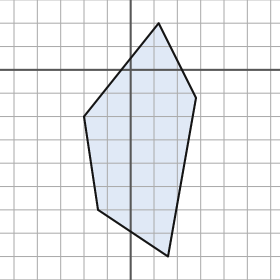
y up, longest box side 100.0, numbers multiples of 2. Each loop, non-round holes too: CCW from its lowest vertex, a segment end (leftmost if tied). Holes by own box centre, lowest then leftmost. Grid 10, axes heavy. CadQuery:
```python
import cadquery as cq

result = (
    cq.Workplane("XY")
    .moveTo(16.0, -80.0)
    .lineTo(28.0, -12.0)
    .lineTo(12.0, 20.0)
    .lineTo(-20.0, -20.0)
    .lineTo(-14.0, -60.0)
    .close()
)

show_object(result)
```